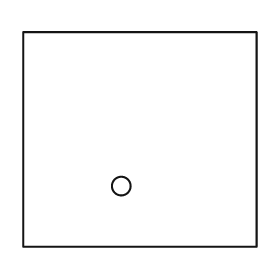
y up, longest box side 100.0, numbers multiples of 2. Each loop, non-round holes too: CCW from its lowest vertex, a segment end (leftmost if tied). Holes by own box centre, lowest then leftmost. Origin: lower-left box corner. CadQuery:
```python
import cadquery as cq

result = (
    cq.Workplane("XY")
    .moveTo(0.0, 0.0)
    .lineTo(100.0, 0.0)
    .lineTo(100.0, 92.0)
    .lineTo(0.0, 92.0)
    .close()
    .moveTo(42.0, 26.0)
    .circle(4.0)
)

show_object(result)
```